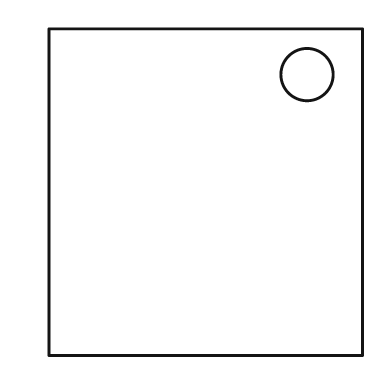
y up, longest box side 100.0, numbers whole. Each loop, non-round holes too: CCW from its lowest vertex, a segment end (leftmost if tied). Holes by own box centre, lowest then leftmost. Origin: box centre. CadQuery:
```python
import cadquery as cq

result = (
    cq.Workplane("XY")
    .moveTo(-48.0, -50.0)
    .lineTo(48.0, -50.0)
    .lineTo(48.0, 50.0)
    .lineTo(-48.0, 50.0)
    .close()
    .moveTo(31.0, 36.0)
    .circle(8.0)
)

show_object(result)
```